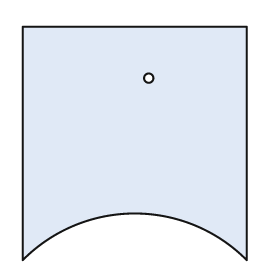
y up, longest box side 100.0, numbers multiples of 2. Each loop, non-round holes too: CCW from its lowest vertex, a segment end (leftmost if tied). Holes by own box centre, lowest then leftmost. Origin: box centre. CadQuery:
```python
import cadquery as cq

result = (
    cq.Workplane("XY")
    .moveTo(-48.0, -50.0)
    .threePointArc((0.0, -30.0), (48.0, -50.0))
    .lineTo(48.0, 50.0)
    .lineTo(-48.0, 50.0)
    .close()
    .moveTo(6.0, 28.0)
    .circle(2.0)
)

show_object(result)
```